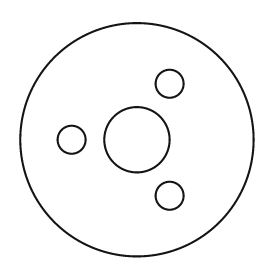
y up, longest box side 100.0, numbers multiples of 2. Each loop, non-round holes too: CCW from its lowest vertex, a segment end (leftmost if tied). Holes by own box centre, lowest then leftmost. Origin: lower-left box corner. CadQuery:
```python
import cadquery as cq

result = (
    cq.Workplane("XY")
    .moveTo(50.0, 50.0)
    .circle(50.0)
    .moveTo(64.0, 26.0)
    .circle(6.0)
    .moveTo(22.0, 50.0)
    .circle(6.0)
    .moveTo(50.0, 50.0)
    .circle(14.0)
    .moveTo(64.0, 74.0)
    .circle(6.0)
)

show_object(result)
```